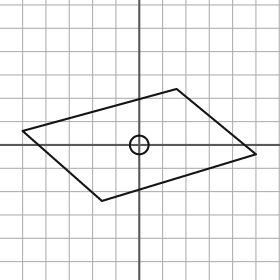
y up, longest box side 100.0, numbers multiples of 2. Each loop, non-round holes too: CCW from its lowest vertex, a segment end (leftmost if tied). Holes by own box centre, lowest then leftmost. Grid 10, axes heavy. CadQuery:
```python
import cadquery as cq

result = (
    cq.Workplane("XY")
    .moveTo(-16.0, -24.0)
    .lineTo(50.0, -4.0)
    .lineTo(16.0, 24.0)
    .lineTo(-50.0, 6.0)
    .close()
    .moveTo(0.0, 0.0)
    .circle(4.0)
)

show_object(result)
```